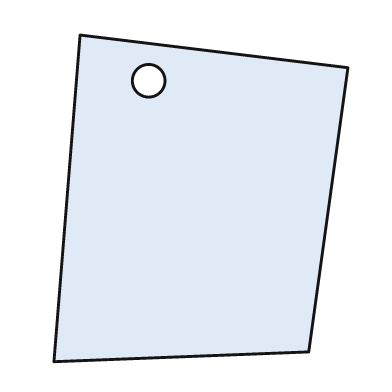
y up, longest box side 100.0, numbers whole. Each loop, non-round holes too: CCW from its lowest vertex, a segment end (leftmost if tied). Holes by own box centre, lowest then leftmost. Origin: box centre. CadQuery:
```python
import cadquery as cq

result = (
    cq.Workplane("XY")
    .moveTo(-45.0, -50.0)
    .lineTo(33.0, -47.0)
    .lineTo(45.0, 40.0)
    .lineTo(-37.0, 50.0)
    .close()
    .moveTo(-16.0, 36.0)
    .circle(5.0)
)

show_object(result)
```